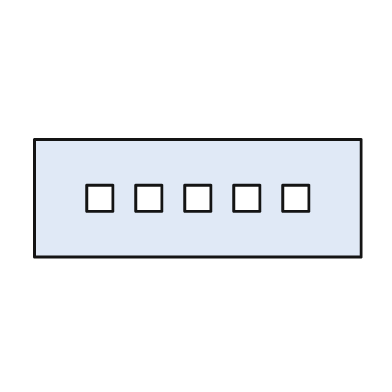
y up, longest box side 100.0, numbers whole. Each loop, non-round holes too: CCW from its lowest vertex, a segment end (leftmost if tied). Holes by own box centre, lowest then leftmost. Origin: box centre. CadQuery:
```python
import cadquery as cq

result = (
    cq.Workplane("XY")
    .moveTo(-50.0, -18.0)
    .lineTo(50.0, -18.0)
    .lineTo(50.0, 18.0)
    .lineTo(-50.0, 18.0)
    .close()
    .moveTo(-34.0, -4.0)
    .lineTo(-26.0, -4.0)
    .lineTo(-26.0, 4.0)
    .lineTo(-34.0, 4.0)
    .close()
    .moveTo(-19.0, -4.0)
    .lineTo(-11.0, -4.0)
    .lineTo(-11.0, 4.0)
    .lineTo(-19.0, 4.0)
    .close()
    .moveTo(-4.0, -4.0)
    .lineTo(4.0, -4.0)
    .lineTo(4.0, 4.0)
    .lineTo(-4.0, 4.0)
    .close()
    .moveTo(11.0, -4.0)
    .lineTo(19.0, -4.0)
    .lineTo(19.0, 4.0)
    .lineTo(11.0, 4.0)
    .close()
    .moveTo(26.0, -4.0)
    .lineTo(34.0, -4.0)
    .lineTo(34.0, 4.0)
    .lineTo(26.0, 4.0)
    .close()
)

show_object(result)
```